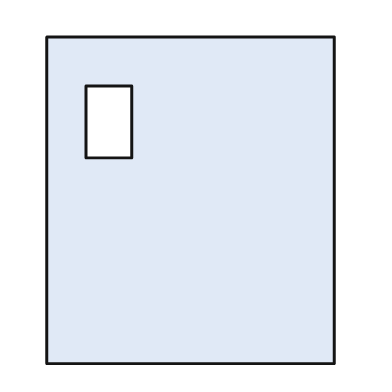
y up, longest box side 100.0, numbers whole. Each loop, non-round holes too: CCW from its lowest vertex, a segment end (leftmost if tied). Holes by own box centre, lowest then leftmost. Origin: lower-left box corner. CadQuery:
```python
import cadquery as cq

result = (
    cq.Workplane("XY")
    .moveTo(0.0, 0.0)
    .lineTo(88.0, 0.0)
    .lineTo(88.0, 100.0)
    .lineTo(0.0, 100.0)
    .close()
    .moveTo(12.0, 63.0)
    .lineTo(26.0, 63.0)
    .lineTo(26.0, 85.0)
    .lineTo(12.0, 85.0)
    .close()
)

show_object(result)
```